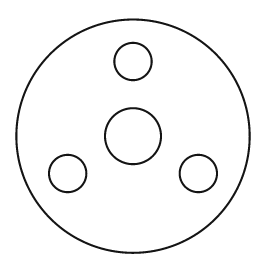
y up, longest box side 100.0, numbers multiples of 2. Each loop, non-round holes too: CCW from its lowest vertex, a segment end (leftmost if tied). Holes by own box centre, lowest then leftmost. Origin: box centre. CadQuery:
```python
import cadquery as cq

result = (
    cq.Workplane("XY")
    .moveTo(0.0, 0.0)
    .circle(50.0)
    .moveTo(-28.0, -16.0)
    .circle(8.0)
    .moveTo(28.0, -16.0)
    .circle(8.0)
    .moveTo(0.0, 0.0)
    .circle(12.0)
    .moveTo(0.0, 32.0)
    .circle(8.0)
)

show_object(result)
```